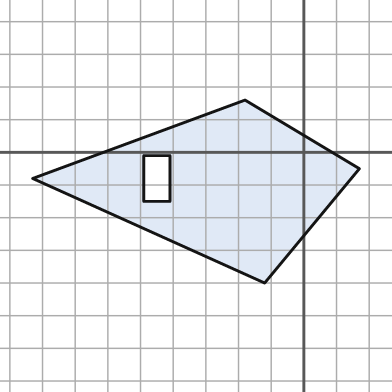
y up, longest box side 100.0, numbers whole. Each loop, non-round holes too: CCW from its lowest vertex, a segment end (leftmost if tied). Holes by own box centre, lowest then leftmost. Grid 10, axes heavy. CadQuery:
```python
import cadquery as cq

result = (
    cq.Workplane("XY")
    .moveTo(-12.0, -40.0)
    .lineTo(17.0, -5.0)
    .lineTo(-18.0, 16.0)
    .lineTo(-83.0, -8.0)
    .close()
    .moveTo(-49.0, -15.0)
    .lineTo(-41.0, -15.0)
    .lineTo(-41.0, -1.0)
    .lineTo(-49.0, -1.0)
    .close()
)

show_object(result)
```